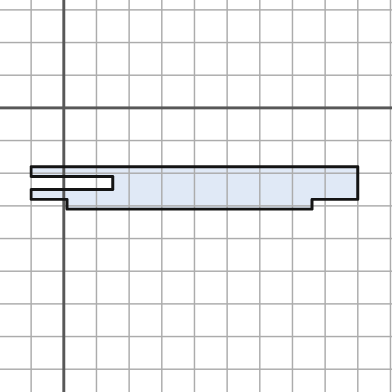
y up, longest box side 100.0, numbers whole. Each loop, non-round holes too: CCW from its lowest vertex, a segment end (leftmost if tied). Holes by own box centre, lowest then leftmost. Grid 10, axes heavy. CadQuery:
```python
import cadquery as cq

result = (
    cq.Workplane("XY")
    .moveTo(1.0, -31.0)
    .lineTo(76.0, -31.0)
    .lineTo(76.0, -28.0)
    .lineTo(90.0, -28.0)
    .lineTo(90.0, -18.0)
    .lineTo(-10.0, -18.0)
    .lineTo(-10.0, -21.0)
    .lineTo(15.0, -21.0)
    .lineTo(15.0, -25.0)
    .lineTo(-10.0, -25.0)
    .lineTo(-10.0, -28.0)
    .lineTo(1.0, -28.0)
    .close()
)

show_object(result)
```